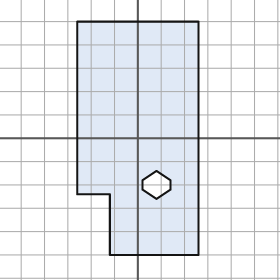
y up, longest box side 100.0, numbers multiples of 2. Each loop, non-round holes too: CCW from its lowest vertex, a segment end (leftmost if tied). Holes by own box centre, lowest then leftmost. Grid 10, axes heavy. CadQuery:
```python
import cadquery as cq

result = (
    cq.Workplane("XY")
    .moveTo(-12.0, -50.0)
    .lineTo(26.0, -50.0)
    .lineTo(26.0, 50.0)
    .lineTo(-26.0, 50.0)
    .lineTo(-26.0, -24.0)
    .lineTo(-12.0, -24.0)
    .close()
    .moveTo(8.0, -26.0)
    .lineTo(14.0, -22.0)
    .lineTo(14.0, -18.0)
    .lineTo(8.0, -14.0)
    .lineTo(2.0, -18.0)
    .lineTo(2.0, -22.0)
    .close()
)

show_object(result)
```